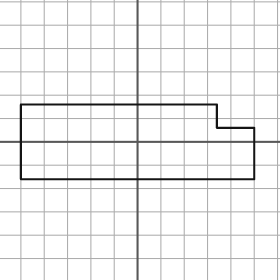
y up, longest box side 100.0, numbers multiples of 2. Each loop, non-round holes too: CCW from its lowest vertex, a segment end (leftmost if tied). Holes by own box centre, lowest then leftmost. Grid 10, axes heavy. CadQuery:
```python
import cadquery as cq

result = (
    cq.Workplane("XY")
    .moveTo(-50.0, -16.0)
    .lineTo(50.0, -16.0)
    .lineTo(50.0, 6.0)
    .lineTo(34.0, 6.0)
    .lineTo(34.0, 16.0)
    .lineTo(-50.0, 16.0)
    .close()
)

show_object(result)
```